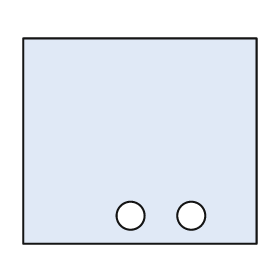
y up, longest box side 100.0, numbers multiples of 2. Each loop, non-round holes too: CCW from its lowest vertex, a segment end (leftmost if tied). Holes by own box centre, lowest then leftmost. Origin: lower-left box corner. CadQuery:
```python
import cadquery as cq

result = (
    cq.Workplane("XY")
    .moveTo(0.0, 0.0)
    .lineTo(100.0, 0.0)
    .lineTo(100.0, 88.0)
    .lineTo(0.0, 88.0)
    .close()
    .moveTo(46.0, 12.0)
    .circle(6.0)
    .moveTo(72.0, 12.0)
    .circle(6.0)
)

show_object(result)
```